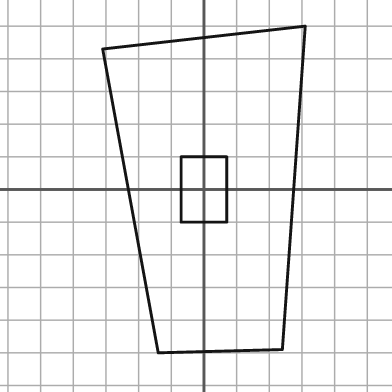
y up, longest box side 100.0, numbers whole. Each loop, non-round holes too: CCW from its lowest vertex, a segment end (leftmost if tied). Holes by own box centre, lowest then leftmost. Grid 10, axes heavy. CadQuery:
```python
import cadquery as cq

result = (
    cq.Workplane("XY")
    .moveTo(-14.0, -50.0)
    .lineTo(24.0, -49.0)
    .lineTo(31.0, 50.0)
    .lineTo(-31.0, 43.0)
    .close()
    .moveTo(-7.0, -10.0)
    .lineTo(7.0, -10.0)
    .lineTo(7.0, 10.0)
    .lineTo(-7.0, 10.0)
    .close()
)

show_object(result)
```